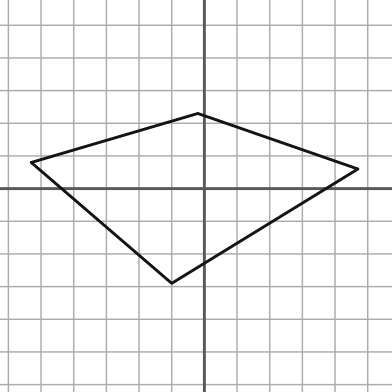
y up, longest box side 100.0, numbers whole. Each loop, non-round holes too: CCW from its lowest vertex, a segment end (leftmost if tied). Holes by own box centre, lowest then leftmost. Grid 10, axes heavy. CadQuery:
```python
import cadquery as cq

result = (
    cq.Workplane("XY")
    .moveTo(-10.0, -29.0)
    .lineTo(47.0, 6.0)
    .lineTo(-2.0, 23.0)
    .lineTo(-53.0, 8.0)
    .close()
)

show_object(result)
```